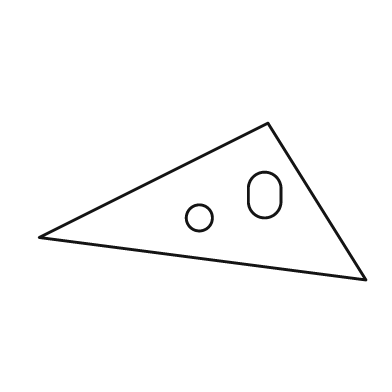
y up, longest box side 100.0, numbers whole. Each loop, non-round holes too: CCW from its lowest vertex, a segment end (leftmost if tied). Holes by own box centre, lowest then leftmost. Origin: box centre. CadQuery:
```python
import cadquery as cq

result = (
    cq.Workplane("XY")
    .moveTo(50.0, -24.0)
    .lineTo(20.0, 24.0)
    .lineTo(-50.0, -11.0)
    .close()
    .moveTo(-1.0, -5.0)
    .circle(4.0)
    .moveTo(14.0, 0.0)
    .threePointArc((19.0, -5.0), (24.0, 0.0))
    .lineTo(24.0, 4.0)
    .threePointArc((19.0, 9.0), (14.0, 4.0))
    .close()
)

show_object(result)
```